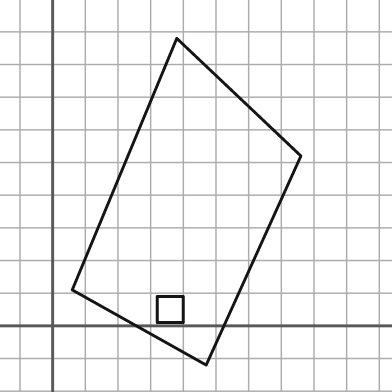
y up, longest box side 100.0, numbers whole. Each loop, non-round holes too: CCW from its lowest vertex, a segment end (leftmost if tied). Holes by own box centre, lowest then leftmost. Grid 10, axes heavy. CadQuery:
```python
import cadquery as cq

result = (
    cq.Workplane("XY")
    .moveTo(47.0, -12.0)
    .lineTo(76.0, 52.0)
    .lineTo(38.0, 88.0)
    .lineTo(6.0, 11.0)
    .close()
    .moveTo(32.0, 1.0)
    .lineTo(40.0, 1.0)
    .lineTo(40.0, 9.0)
    .lineTo(32.0, 9.0)
    .close()
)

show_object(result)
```